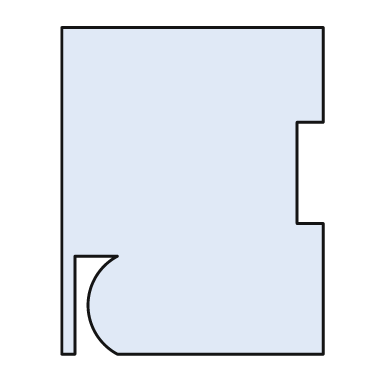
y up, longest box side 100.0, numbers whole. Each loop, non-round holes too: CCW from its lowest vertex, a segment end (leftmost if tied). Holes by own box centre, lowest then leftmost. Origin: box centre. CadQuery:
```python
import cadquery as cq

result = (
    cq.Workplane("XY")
    .moveTo(-40.0, -50.0)
    .lineTo(-36.0, -50.0)
    .lineTo(-36.0, -20.0)
    .lineTo(-23.0, -20.0)
    .threePointArc((-32.0, -35.0), (-23.0, -50.0))
    .lineTo(40.0, -50.0)
    .lineTo(40.0, -10.0)
    .lineTo(32.0, -10.0)
    .lineTo(32.0, 21.0)
    .lineTo(40.0, 21.0)
    .lineTo(40.0, 50.0)
    .lineTo(-40.0, 50.0)
    .close()
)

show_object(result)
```